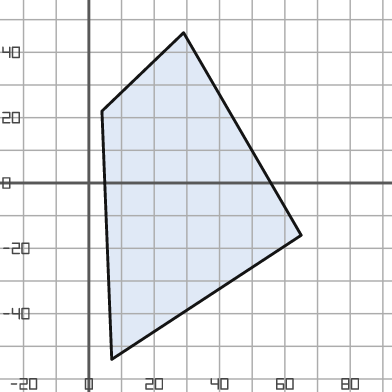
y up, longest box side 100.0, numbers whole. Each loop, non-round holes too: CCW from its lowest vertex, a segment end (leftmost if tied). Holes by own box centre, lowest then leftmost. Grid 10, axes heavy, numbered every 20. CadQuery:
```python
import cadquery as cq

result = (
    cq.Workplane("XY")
    .moveTo(7.0, -54.0)
    .lineTo(65.0, -16.0)
    .lineTo(29.0, 46.0)
    .lineTo(4.0, 22.0)
    .close()
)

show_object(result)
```